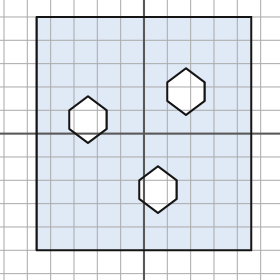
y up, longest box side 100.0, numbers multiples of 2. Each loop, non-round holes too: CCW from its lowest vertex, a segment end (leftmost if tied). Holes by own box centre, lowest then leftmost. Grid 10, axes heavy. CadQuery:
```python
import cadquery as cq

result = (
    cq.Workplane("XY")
    .moveTo(-46.0, -50.0)
    .lineTo(46.0, -50.0)
    .lineTo(46.0, 50.0)
    .lineTo(-46.0, 50.0)
    .close()
    .moveTo(6.0, -34.0)
    .lineTo(14.0, -28.0)
    .lineTo(14.0, -20.0)
    .lineTo(6.0, -14.0)
    .lineTo(-2.0, -20.0)
    .lineTo(-2.0, -28.0)
    .close()
    .moveTo(-24.0, -4.0)
    .lineTo(-16.0, 2.0)
    .lineTo(-16.0, 10.0)
    .lineTo(-24.0, 16.0)
    .lineTo(-32.0, 10.0)
    .lineTo(-32.0, 2.0)
    .close()
    .moveTo(18.0, 8.0)
    .lineTo(26.0, 14.0)
    .lineTo(26.0, 22.0)
    .lineTo(18.0, 28.0)
    .lineTo(10.0, 22.0)
    .lineTo(10.0, 14.0)
    .close()
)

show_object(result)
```